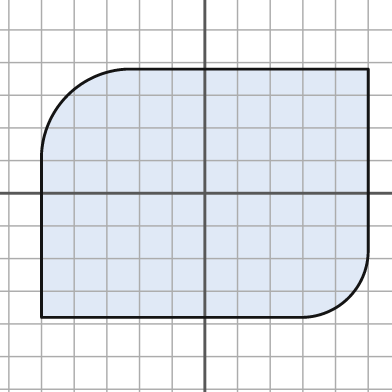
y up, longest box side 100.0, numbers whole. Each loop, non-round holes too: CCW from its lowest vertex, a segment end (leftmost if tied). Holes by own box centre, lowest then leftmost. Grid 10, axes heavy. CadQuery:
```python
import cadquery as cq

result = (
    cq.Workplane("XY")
    .moveTo(-50.0, -38.0)
    .lineTo(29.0, -38.0)
    .threePointArc((44.0, -32.0), (50.0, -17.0))
    .lineTo(50.0, 38.0)
    .lineTo(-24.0, 38.0)
    .threePointArc((-42.0, 30.0), (-50.0, 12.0))
    .close()
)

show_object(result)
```